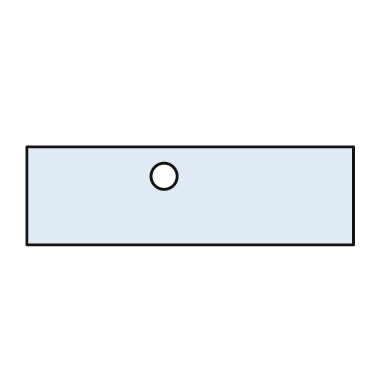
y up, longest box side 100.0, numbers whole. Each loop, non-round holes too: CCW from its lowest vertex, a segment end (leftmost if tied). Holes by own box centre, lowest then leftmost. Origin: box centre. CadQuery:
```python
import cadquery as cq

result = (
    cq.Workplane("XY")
    .moveTo(-50.0, -15.0)
    .lineTo(50.0, -15.0)
    .lineTo(50.0, 15.0)
    .lineTo(-50.0, 15.0)
    .close()
    .moveTo(-8.0, 6.0)
    .circle(4.0)
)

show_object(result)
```